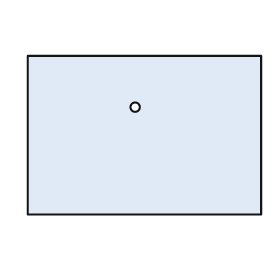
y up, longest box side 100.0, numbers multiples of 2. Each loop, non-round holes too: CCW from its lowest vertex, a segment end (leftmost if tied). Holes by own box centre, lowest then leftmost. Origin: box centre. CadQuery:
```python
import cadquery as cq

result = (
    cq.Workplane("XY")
    .moveTo(-50.0, -34.0)
    .lineTo(50.0, -34.0)
    .lineTo(50.0, 34.0)
    .lineTo(-50.0, 34.0)
    .close()
    .moveTo(-4.0, 12.0)
    .circle(2.0)
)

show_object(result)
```